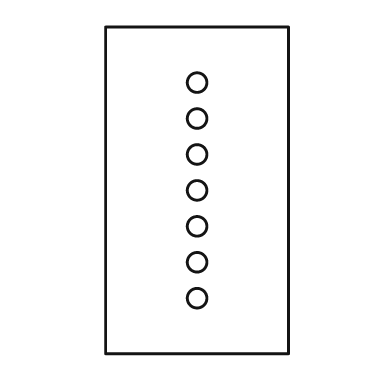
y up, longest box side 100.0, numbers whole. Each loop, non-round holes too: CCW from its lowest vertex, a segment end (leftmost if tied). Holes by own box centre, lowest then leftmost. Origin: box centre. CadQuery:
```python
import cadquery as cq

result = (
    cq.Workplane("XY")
    .moveTo(-28.0, -50.0)
    .lineTo(28.0, -50.0)
    .lineTo(28.0, 50.0)
    .lineTo(-28.0, 50.0)
    .close()
    .moveTo(0.0, -33.0)
    .circle(3.0)
    .moveTo(0.0, -22.0)
    .circle(3.0)
    .moveTo(0.0, -11.0)
    .circle(3.0)
    .moveTo(0.0, 0.0)
    .circle(3.0)
    .moveTo(0.0, 11.0)
    .circle(3.0)
    .moveTo(0.0, 22.0)
    .circle(3.0)
    .moveTo(0.0, 33.0)
    .circle(3.0)
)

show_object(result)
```